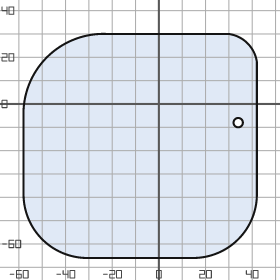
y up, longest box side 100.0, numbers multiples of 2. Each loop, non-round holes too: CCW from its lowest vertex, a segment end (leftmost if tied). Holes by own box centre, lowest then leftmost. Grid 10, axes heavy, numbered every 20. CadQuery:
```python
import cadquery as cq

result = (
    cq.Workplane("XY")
    .moveTo(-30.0, -66.0)
    .lineTo(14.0, -66.0)
    .threePointArc((34.0, -58.0), (42.0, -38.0))
    .lineTo(42.0, 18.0)
    .threePointArc((38.0, 26.0), (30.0, 30.0))
    .lineTo(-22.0, 30.0)
    .threePointArc((-48.0, 20.0), (-58.0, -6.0))
    .lineTo(-58.0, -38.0)
    .threePointArc((-50.0, -58.0), (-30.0, -66.0))
    .close()
    .moveTo(34.0, -8.0)
    .circle(2.0)
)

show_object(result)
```